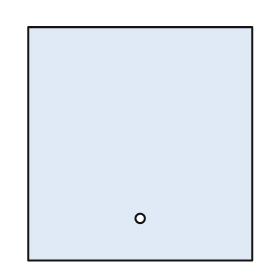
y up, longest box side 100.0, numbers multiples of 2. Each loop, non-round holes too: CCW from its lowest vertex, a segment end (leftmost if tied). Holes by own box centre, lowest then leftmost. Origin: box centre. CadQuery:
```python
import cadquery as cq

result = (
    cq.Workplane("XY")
    .moveTo(-48.0, -50.0)
    .lineTo(48.0, -50.0)
    .lineTo(48.0, 50.0)
    .lineTo(-48.0, 50.0)
    .close()
    .moveTo(0.0, -32.0)
    .circle(2.0)
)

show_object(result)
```